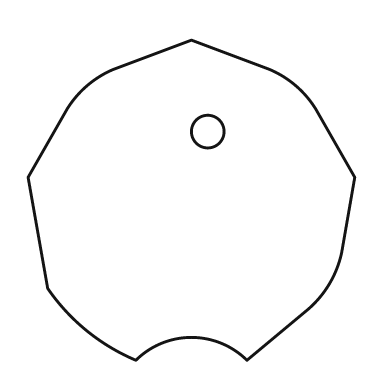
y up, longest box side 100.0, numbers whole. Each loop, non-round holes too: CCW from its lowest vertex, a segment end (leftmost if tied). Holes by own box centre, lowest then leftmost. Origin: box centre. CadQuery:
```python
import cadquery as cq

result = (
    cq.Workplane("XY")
    .moveTo(-17.0, -49.0)
    .threePointArc((0.0, -42.0), (17.0, -49.0))
    .lineTo(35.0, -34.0)
    .threePointArc((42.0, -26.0), (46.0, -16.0))
    .lineTo(50.0, 7.0)
    .lineTo(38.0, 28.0)
    .threePointArc((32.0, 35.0), (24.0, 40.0))
    .lineTo(0.0, 49.0)
    .lineTo(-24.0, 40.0)
    .threePointArc((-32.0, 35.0), (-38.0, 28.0))
    .lineTo(-50.0, 7.0)
    .lineTo(-44.0, -27.0)
    .threePointArc((-32.0, -40.0), (-17.0, -49.0))
    .close()
    .moveTo(5.0, 21.0)
    .circle(5.0)
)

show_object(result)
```